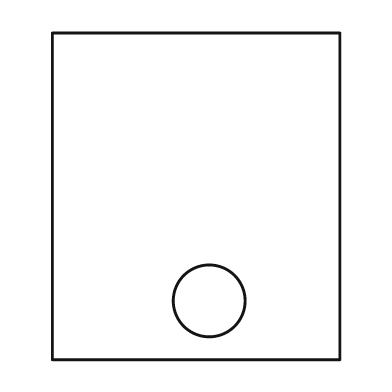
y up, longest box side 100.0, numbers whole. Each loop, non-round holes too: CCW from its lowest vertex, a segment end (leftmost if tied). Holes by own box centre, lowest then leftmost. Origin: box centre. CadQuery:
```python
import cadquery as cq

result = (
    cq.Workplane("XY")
    .moveTo(-44.0, -50.0)
    .lineTo(44.0, -50.0)
    .lineTo(44.0, 50.0)
    .lineTo(-44.0, 50.0)
    .close()
    .moveTo(4.0, -32.0)
    .circle(11.0)
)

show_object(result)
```